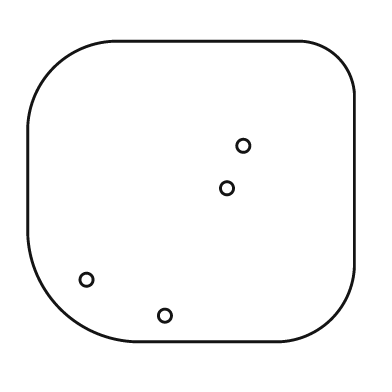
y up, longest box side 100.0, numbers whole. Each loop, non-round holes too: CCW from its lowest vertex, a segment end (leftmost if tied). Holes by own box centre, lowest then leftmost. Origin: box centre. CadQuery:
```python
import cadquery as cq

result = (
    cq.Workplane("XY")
    .moveTo(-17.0, -46.0)
    .lineTo(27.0, -46.0)
    .threePointArc((43.0, -39.0), (50.0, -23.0))
    .lineTo(50.0, 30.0)
    .threePointArc((45.0, 41.0), (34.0, 46.0))
    .lineTo(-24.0, 46.0)
    .threePointArc((-42.0, 38.0), (-50.0, 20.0))
    .lineTo(-50.0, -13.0)
    .threePointArc((-40.0, -36.0), (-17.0, -46.0))
    .close()
    .moveTo(-8.0, -38.0)
    .circle(2.0)
    .moveTo(-32.0, -27.0)
    .circle(2.0)
    .moveTo(11.0, 1.0)
    .circle(2.0)
    .moveTo(16.0, 14.0)
    .circle(2.0)
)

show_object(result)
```